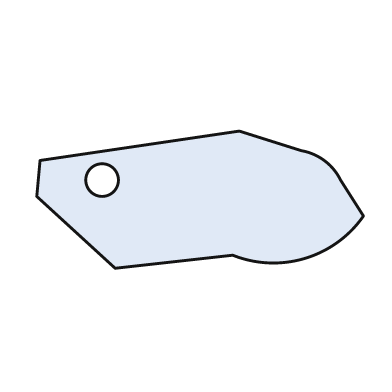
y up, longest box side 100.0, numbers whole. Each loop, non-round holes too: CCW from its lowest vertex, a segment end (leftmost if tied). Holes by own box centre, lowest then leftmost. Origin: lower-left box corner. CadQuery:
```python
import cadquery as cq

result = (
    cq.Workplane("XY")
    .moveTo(24.0, 0.0)
    .lineTo(60.0, 4.0)
    .threePointArc((82.0, 3.0), (100.0, 16.0))
    .lineTo(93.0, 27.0)
    .threePointArc((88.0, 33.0), (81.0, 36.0))
    .lineTo(62.0, 42.0)
    .lineTo(1.0, 33.0)
    .lineTo(0.0, 22.0)
    .close()
    .moveTo(20.0, 27.0)
    .circle(5.0)
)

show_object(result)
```